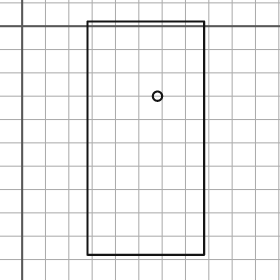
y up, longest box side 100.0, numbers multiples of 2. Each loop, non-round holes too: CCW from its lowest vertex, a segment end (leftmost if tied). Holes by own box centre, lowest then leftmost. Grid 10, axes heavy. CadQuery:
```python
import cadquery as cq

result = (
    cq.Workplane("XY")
    .moveTo(28.0, -98.0)
    .lineTo(78.0, -98.0)
    .lineTo(78.0, 2.0)
    .lineTo(28.0, 2.0)
    .close()
    .moveTo(58.0, -30.0)
    .circle(2.0)
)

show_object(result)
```